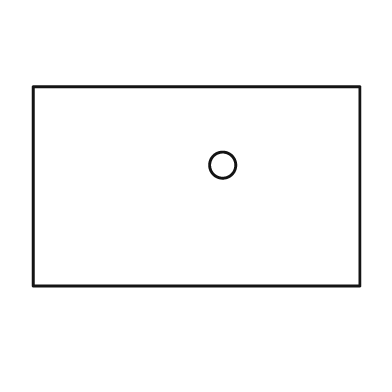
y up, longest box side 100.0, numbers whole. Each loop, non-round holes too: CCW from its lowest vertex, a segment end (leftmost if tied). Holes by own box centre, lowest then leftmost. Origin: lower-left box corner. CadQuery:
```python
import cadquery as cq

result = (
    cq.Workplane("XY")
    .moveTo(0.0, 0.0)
    .lineTo(100.0, 0.0)
    .lineTo(100.0, 61.0)
    .lineTo(0.0, 61.0)
    .close()
    .moveTo(58.0, 37.0)
    .circle(4.0)
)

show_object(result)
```